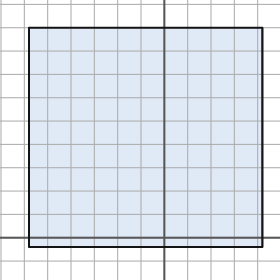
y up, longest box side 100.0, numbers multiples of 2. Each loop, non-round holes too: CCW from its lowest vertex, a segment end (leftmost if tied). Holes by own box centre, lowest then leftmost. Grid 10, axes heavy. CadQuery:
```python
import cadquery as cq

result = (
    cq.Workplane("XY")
    .moveTo(-58.0, -4.0)
    .lineTo(42.0, -4.0)
    .lineTo(42.0, 90.0)
    .lineTo(-58.0, 90.0)
    .close()
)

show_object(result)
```